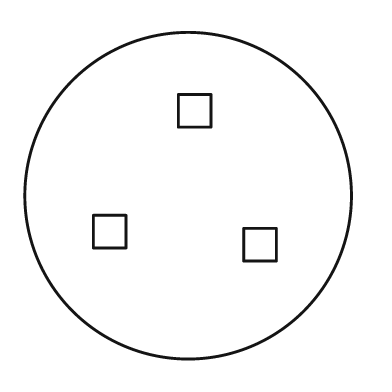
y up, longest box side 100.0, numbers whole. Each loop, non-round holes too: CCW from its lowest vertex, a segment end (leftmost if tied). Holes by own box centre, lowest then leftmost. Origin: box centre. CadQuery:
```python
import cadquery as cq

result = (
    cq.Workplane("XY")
    .moveTo(0.0, 0.0)
    .circle(50.0)
    .moveTo(17.0, -20.0)
    .lineTo(27.0, -20.0)
    .lineTo(27.0, -10.0)
    .lineTo(17.0, -10.0)
    .close()
    .moveTo(-29.0, -16.0)
    .lineTo(-19.0, -16.0)
    .lineTo(-19.0, -6.0)
    .lineTo(-29.0, -6.0)
    .close()
    .moveTo(-3.0, 21.0)
    .lineTo(7.0, 21.0)
    .lineTo(7.0, 31.0)
    .lineTo(-3.0, 31.0)
    .close()
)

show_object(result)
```